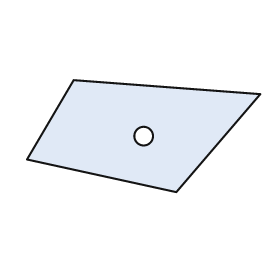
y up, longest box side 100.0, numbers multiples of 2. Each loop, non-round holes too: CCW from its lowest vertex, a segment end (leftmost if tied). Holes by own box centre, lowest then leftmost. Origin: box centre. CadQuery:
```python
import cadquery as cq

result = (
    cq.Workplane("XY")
    .moveTo(14.0, -24.0)
    .lineTo(50.0, 18.0)
    .lineTo(-30.0, 24.0)
    .lineTo(-50.0, -10.0)
    .close()
    .moveTo(0.0, 0.0)
    .circle(4.0)
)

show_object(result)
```